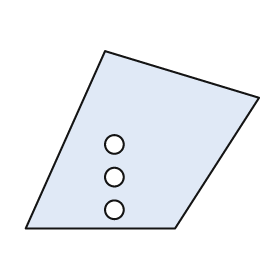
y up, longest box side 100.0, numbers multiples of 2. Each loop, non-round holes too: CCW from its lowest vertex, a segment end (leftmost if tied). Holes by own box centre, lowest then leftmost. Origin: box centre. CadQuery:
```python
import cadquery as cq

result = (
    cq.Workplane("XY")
    .moveTo(-50.0, -38.0)
    .lineTo(14.0, -38.0)
    .lineTo(50.0, 18.0)
    .lineTo(-16.0, 38.0)
    .close()
    .moveTo(-12.0, -30.0)
    .circle(4.0)
    .moveTo(-12.0, -16.0)
    .circle(4.0)
    .moveTo(-12.0, -2.0)
    .circle(4.0)
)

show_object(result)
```